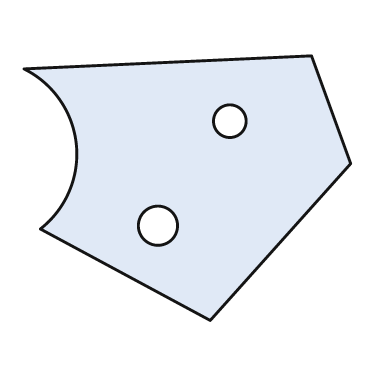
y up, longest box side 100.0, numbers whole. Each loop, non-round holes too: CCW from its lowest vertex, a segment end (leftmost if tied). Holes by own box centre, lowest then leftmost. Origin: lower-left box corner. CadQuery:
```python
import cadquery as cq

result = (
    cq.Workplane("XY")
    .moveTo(57.0, 0.0)
    .lineTo(100.0, 48.0)
    .lineTo(88.0, 81.0)
    .lineTo(0.0, 77.0)
    .threePointArc((16.0, 54.0), (5.0, 28.0))
    .close()
    .moveTo(41.0, 29.0)
    .circle(6.0)
    .moveTo(63.0, 61.0)
    .circle(5.0)
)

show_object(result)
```